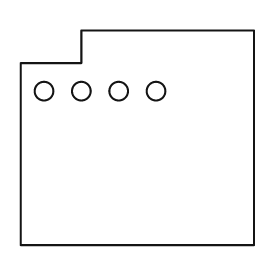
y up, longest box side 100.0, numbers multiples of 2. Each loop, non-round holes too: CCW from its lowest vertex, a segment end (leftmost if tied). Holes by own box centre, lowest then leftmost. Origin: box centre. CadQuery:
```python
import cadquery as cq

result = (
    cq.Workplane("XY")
    .moveTo(-50.0, -46.0)
    .lineTo(50.0, -46.0)
    .lineTo(50.0, 46.0)
    .lineTo(-24.0, 46.0)
    .lineTo(-24.0, 32.0)
    .lineTo(-50.0, 32.0)
    .close()
    .moveTo(-40.0, 20.0)
    .circle(4.0)
    .moveTo(-24.0, 20.0)
    .circle(4.0)
    .moveTo(-8.0, 20.0)
    .circle(4.0)
    .moveTo(8.0, 20.0)
    .circle(4.0)
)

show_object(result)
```